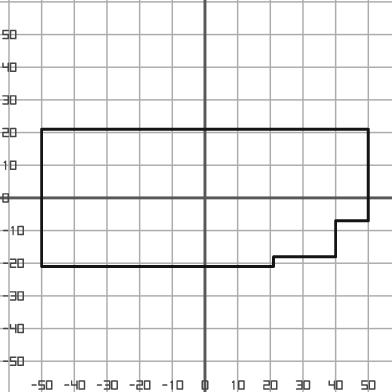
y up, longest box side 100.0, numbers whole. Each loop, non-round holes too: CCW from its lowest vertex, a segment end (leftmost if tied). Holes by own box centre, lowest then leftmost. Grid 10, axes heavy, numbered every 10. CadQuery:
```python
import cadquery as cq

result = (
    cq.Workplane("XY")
    .moveTo(-50.0, -21.0)
    .lineTo(21.0, -21.0)
    .lineTo(21.0, -18.0)
    .lineTo(40.0, -18.0)
    .lineTo(40.0, -7.0)
    .lineTo(50.0, -7.0)
    .lineTo(50.0, 21.0)
    .lineTo(-50.0, 21.0)
    .close()
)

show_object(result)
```